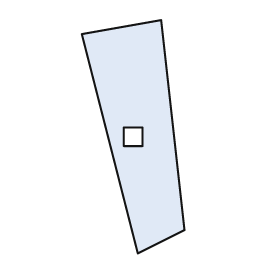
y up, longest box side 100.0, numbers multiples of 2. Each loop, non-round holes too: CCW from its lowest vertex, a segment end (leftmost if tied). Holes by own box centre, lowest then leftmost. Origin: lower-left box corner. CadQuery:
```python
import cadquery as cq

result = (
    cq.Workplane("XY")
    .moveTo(24.0, 0.0)
    .lineTo(44.0, 10.0)
    .lineTo(34.0, 100.0)
    .lineTo(0.0, 94.0)
    .close()
    .moveTo(18.0, 46.0)
    .lineTo(26.0, 46.0)
    .lineTo(26.0, 54.0)
    .lineTo(18.0, 54.0)
    .close()
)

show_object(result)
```